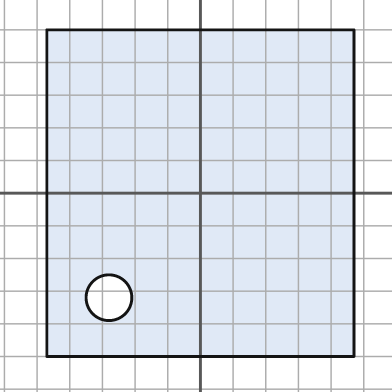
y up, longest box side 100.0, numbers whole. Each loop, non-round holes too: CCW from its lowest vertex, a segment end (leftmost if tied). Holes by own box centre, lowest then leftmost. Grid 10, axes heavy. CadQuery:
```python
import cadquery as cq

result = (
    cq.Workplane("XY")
    .moveTo(-47.0, -50.0)
    .lineTo(47.0, -50.0)
    .lineTo(47.0, 50.0)
    .lineTo(-47.0, 50.0)
    .close()
    .moveTo(-28.0, -32.0)
    .circle(7.0)
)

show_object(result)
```